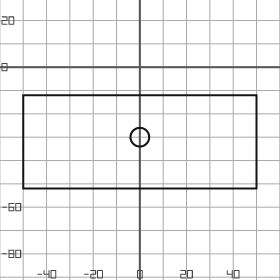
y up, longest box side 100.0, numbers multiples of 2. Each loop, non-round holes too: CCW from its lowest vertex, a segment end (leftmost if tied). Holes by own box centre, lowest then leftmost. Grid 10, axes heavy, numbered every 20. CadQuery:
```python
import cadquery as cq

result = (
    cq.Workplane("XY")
    .moveTo(-50.0, -52.0)
    .lineTo(50.0, -52.0)
    .lineTo(50.0, -12.0)
    .lineTo(-50.0, -12.0)
    .close()
    .moveTo(0.0, -30.0)
    .circle(4.0)
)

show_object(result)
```